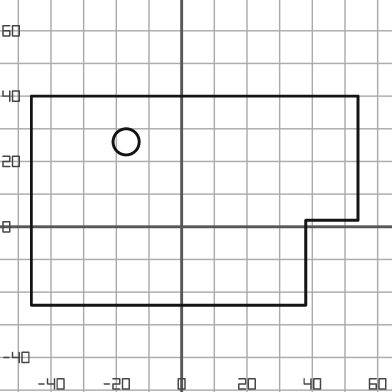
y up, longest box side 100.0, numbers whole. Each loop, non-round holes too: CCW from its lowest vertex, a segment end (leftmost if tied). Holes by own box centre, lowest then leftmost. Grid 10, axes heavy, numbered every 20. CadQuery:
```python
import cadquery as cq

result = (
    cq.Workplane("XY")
    .moveTo(-46.0, -24.0)
    .lineTo(38.0, -24.0)
    .lineTo(38.0, 2.0)
    .lineTo(54.0, 2.0)
    .lineTo(54.0, 40.0)
    .lineTo(-46.0, 40.0)
    .close()
    .moveTo(-17.0, 26.0)
    .circle(4.0)
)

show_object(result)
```